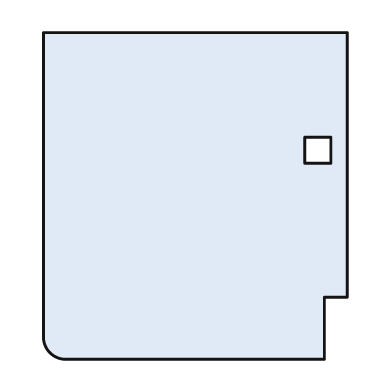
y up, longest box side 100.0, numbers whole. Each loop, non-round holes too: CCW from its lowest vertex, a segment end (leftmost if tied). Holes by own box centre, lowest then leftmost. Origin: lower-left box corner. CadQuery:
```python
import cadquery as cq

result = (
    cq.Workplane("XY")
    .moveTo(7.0, 0.0)
    .lineTo(86.0, 0.0)
    .lineTo(86.0, 19.0)
    .lineTo(93.0, 19.0)
    .lineTo(93.0, 100.0)
    .lineTo(0.0, 100.0)
    .lineTo(0.0, 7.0)
    .threePointArc((2.0, 2.0), (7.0, 0.0))
    .close()
    .moveTo(80.0, 60.0)
    .lineTo(88.0, 60.0)
    .lineTo(88.0, 68.0)
    .lineTo(80.0, 68.0)
    .close()
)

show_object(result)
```